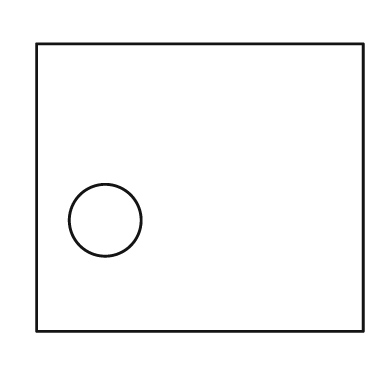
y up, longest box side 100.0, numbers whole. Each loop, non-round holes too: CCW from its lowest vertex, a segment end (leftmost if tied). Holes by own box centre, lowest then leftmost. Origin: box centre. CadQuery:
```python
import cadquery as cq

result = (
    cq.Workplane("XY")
    .moveTo(-50.0, -44.0)
    .lineTo(50.0, -44.0)
    .lineTo(50.0, 44.0)
    .lineTo(-50.0, 44.0)
    .close()
    .moveTo(-29.0, -10.0)
    .circle(11.0)
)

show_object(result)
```